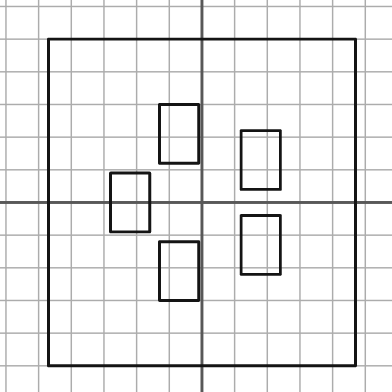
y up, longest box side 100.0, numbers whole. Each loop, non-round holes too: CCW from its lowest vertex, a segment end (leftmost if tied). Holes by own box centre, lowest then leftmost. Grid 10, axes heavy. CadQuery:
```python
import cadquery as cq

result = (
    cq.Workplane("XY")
    .moveTo(-47.0, -50.0)
    .lineTo(47.0, -50.0)
    .lineTo(47.0, 50.0)
    .lineTo(-47.0, 50.0)
    .close()
    .moveTo(-13.0, -30.0)
    .lineTo(-1.0, -30.0)
    .lineTo(-1.0, -12.0)
    .lineTo(-13.0, -12.0)
    .close()
    .moveTo(12.0, -22.0)
    .lineTo(24.0, -22.0)
    .lineTo(24.0, -4.0)
    .lineTo(12.0, -4.0)
    .close()
    .moveTo(-28.0, -9.0)
    .lineTo(-16.0, -9.0)
    .lineTo(-16.0, 9.0)
    .lineTo(-28.0, 9.0)
    .close()
    .moveTo(12.0, 4.0)
    .lineTo(24.0, 4.0)
    .lineTo(24.0, 22.0)
    .lineTo(12.0, 22.0)
    .close()
    .moveTo(-13.0, 12.0)
    .lineTo(-1.0, 12.0)
    .lineTo(-1.0, 30.0)
    .lineTo(-13.0, 30.0)
    .close()
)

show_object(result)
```